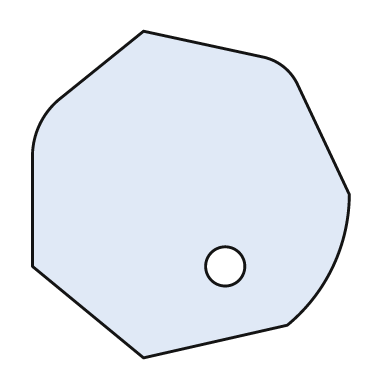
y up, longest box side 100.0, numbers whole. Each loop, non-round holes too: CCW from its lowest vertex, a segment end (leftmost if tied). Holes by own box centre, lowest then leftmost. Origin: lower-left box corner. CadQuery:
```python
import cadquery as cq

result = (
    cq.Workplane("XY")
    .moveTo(34.0, 0.0)
    .lineTo(78.0, 10.0)
    .threePointArc((92.0, 28.0), (97.0, 50.0))
    .lineTo(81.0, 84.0)
    .threePointArc((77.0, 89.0), (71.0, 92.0))
    .lineTo(34.0, 100.0)
    .lineTo(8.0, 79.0)
    .threePointArc((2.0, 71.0), (0.0, 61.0))
    .lineTo(0.0, 28.0)
    .close()
    .moveTo(59.0, 28.0)
    .circle(6.0)
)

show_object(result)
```